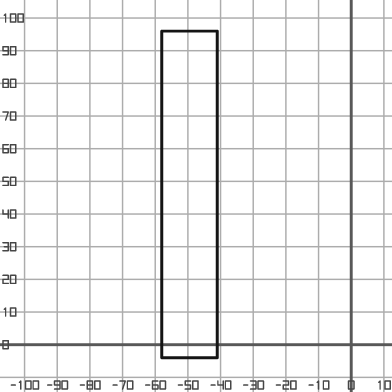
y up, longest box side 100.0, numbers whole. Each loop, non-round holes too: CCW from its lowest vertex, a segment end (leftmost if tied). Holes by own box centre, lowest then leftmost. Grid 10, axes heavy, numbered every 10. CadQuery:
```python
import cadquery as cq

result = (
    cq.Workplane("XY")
    .moveTo(-58.0, -4.0)
    .lineTo(-41.0, -4.0)
    .lineTo(-41.0, 96.0)
    .lineTo(-58.0, 96.0)
    .close()
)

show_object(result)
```